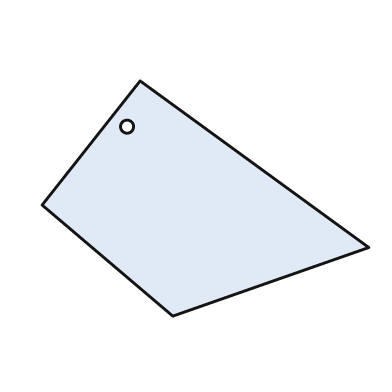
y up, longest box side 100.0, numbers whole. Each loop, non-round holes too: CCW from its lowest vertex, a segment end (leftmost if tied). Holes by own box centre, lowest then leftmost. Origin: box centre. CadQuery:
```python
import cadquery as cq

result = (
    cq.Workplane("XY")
    .moveTo(-10.0, -36.0)
    .lineTo(50.0, -15.0)
    .lineTo(-20.0, 36.0)
    .lineTo(-50.0, -2.0)
    .close()
    .moveTo(-24.0, 22.0)
    .circle(2.0)
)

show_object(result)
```